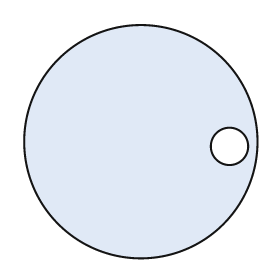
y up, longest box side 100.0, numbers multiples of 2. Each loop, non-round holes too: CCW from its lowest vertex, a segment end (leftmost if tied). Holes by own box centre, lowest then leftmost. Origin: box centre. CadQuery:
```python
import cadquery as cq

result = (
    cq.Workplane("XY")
    .moveTo(0.0, 0.0)
    .circle(50.0)
    .moveTo(38.0, -2.0)
    .circle(8.0)
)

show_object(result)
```